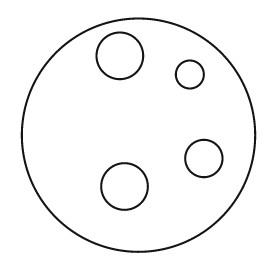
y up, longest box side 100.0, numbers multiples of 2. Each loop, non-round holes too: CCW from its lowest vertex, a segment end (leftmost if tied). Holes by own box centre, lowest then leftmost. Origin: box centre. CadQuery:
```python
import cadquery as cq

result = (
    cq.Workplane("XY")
    .moveTo(0.0, 0.0)
    .circle(50.0)
    .moveTo(-6.0, -22.0)
    .circle(10.0)
    .moveTo(28.0, -10.0)
    .circle(8.0)
    .moveTo(22.0, 26.0)
    .circle(6.0)
    .moveTo(-8.0, 34.0)
    .circle(10.0)
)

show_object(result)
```